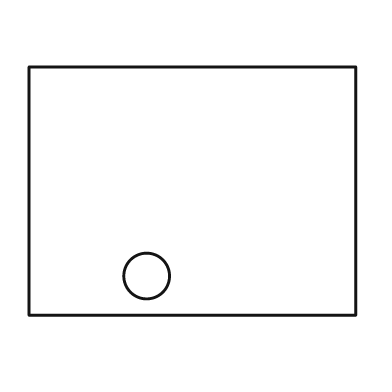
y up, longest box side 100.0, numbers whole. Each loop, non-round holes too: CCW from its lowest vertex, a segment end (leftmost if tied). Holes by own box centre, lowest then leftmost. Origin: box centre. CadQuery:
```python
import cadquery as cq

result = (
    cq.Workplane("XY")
    .moveTo(-50.0, -38.0)
    .lineTo(50.0, -38.0)
    .lineTo(50.0, 38.0)
    .lineTo(-50.0, 38.0)
    .close()
    .moveTo(-14.0, -26.0)
    .circle(7.0)
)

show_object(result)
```